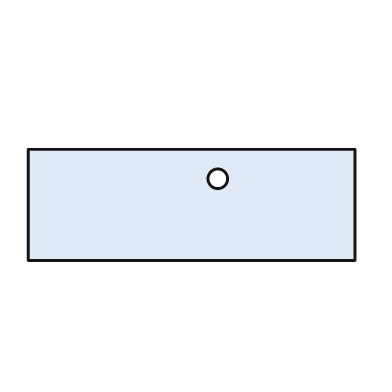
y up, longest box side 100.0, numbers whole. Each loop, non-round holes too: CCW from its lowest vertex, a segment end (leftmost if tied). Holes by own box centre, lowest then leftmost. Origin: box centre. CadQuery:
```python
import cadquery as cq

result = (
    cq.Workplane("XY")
    .moveTo(-50.0, -17.0)
    .lineTo(50.0, -17.0)
    .lineTo(50.0, 17.0)
    .lineTo(-50.0, 17.0)
    .close()
    .moveTo(8.0, 8.0)
    .circle(3.0)
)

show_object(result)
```